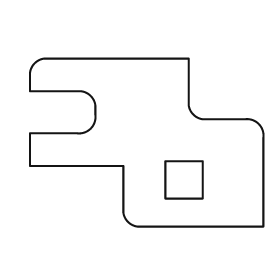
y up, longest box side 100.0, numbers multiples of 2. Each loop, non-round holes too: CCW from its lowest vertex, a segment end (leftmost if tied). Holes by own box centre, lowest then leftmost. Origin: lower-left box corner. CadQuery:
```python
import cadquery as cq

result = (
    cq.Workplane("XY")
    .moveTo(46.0, 0.0)
    .lineTo(100.0, 0.0)
    .lineTo(100.0, 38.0)
    .threePointArc((98.0, 44.0), (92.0, 46.0))
    .lineTo(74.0, 46.0)
    .threePointArc((70.0, 48.0), (68.0, 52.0))
    .lineTo(68.0, 72.0)
    .lineTo(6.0, 72.0)
    .threePointArc((2.0, 70.0), (0.0, 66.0))
    .lineTo(0.0, 58.0)
    .lineTo(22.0, 58.0)
    .threePointArc((26.0, 56.0), (28.0, 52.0))
    .lineTo(28.0, 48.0)
    .threePointArc((26.0, 42.0), (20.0, 40.0))
    .lineTo(0.0, 40.0)
    .lineTo(0.0, 26.0)
    .lineTo(40.0, 26.0)
    .lineTo(40.0, 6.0)
    .threePointArc((42.0, 2.0), (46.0, 0.0))
    .close()
    .moveTo(58.0, 12.0)
    .lineTo(74.0, 12.0)
    .lineTo(74.0, 28.0)
    .lineTo(58.0, 28.0)
    .close()
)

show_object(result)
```